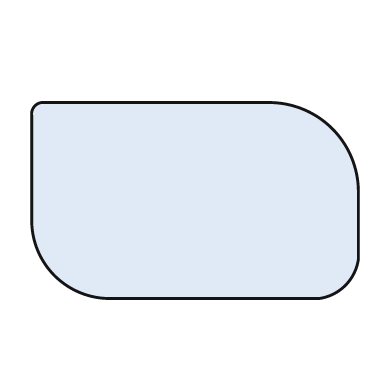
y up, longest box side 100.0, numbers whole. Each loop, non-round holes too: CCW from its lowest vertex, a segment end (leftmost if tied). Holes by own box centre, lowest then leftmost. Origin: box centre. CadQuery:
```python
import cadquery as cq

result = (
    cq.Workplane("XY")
    .moveTo(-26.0, -30.0)
    .lineTo(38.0, -30.0)
    .threePointArc((46.0, -26.0), (50.0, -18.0))
    .lineTo(50.0, 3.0)
    .threePointArc((42.0, 22.0), (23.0, 30.0))
    .lineTo(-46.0, 30.0)
    .threePointArc((-49.0, 29.0), (-50.0, 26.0))
    .lineTo(-50.0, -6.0)
    .threePointArc((-43.0, -23.0), (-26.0, -30.0))
    .close()
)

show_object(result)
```